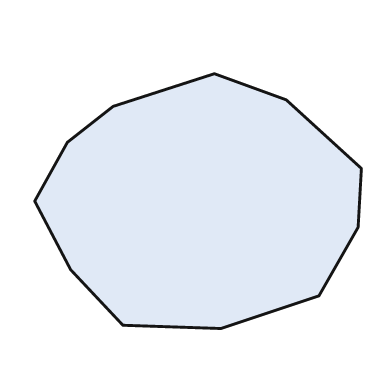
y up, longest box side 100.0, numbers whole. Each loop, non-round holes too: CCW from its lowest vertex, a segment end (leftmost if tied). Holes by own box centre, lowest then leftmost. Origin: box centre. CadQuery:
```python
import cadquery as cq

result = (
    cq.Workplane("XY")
    .moveTo(7.0, -39.0)
    .lineTo(37.0, -29.0)
    .lineTo(49.0, -8.0)
    .lineTo(50.0, 10.0)
    .lineTo(27.0, 31.0)
    .lineTo(5.0, 39.0)
    .lineTo(-26.0, 29.0)
    .lineTo(-40.0, 18.0)
    .lineTo(-50.0, 0.0)
    .lineTo(-39.0, -21.0)
    .lineTo(-23.0, -38.0)
    .close()
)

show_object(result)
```